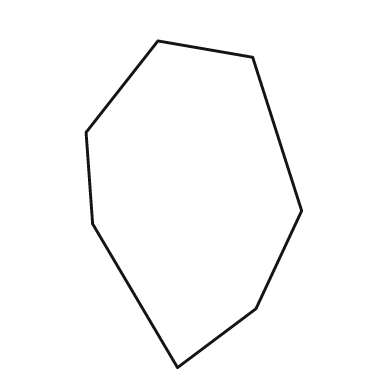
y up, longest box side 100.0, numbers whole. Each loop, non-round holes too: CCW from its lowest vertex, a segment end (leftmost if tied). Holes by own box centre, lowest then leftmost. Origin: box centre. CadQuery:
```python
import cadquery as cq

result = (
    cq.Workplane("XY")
    .moveTo(-5.0, -50.0)
    .lineTo(19.0, -32.0)
    .lineTo(33.0, -2.0)
    .lineTo(18.0, 45.0)
    .lineTo(-11.0, 50.0)
    .lineTo(-33.0, 22.0)
    .lineTo(-31.0, -6.0)
    .close()
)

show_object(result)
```